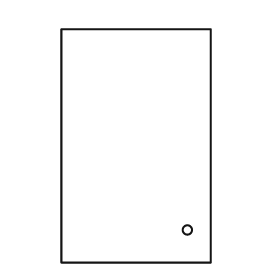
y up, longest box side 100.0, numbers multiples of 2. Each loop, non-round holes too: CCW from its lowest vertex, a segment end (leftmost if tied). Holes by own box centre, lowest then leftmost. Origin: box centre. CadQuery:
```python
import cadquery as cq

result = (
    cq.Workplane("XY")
    .moveTo(-32.0, -50.0)
    .lineTo(32.0, -50.0)
    .lineTo(32.0, 50.0)
    .lineTo(-32.0, 50.0)
    .close()
    .moveTo(22.0, -36.0)
    .circle(2.0)
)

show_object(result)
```